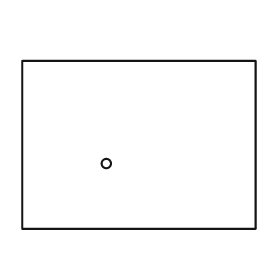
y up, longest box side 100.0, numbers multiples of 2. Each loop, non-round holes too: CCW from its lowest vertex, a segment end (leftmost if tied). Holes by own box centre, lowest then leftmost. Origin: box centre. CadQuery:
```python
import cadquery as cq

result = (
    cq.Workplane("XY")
    .moveTo(-50.0, -36.0)
    .lineTo(50.0, -36.0)
    .lineTo(50.0, 36.0)
    .lineTo(-50.0, 36.0)
    .close()
    .moveTo(-14.0, -8.0)
    .circle(2.0)
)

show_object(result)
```